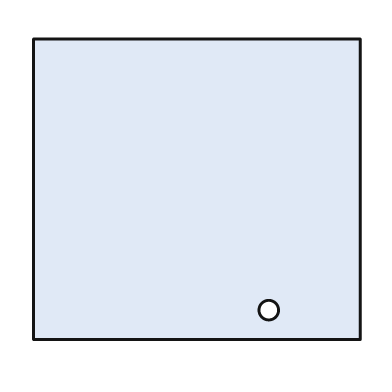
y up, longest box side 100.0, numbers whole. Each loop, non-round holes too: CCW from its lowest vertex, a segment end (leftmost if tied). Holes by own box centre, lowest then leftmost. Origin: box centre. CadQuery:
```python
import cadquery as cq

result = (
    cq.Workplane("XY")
    .moveTo(-50.0, -46.0)
    .lineTo(50.0, -46.0)
    .lineTo(50.0, 46.0)
    .lineTo(-50.0, 46.0)
    .close()
    .moveTo(22.0, -37.0)
    .circle(3.0)
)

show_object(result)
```